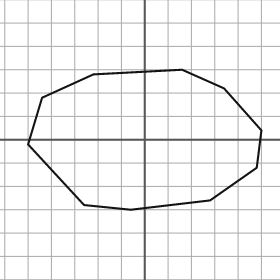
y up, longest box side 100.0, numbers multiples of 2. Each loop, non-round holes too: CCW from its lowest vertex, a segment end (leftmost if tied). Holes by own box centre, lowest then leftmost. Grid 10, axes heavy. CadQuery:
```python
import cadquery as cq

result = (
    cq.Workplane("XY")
    .moveTo(-6.0, -30.0)
    .lineTo(28.0, -26.0)
    .lineTo(48.0, -12.0)
    .lineTo(50.0, 4.0)
    .lineTo(34.0, 22.0)
    .lineTo(16.0, 30.0)
    .lineTo(-22.0, 28.0)
    .lineTo(-44.0, 18.0)
    .lineTo(-50.0, -2.0)
    .lineTo(-26.0, -28.0)
    .close()
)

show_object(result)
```